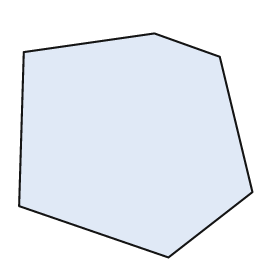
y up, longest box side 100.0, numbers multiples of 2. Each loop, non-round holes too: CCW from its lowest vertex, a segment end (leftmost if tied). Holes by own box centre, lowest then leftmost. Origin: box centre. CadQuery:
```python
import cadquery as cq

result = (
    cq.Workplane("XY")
    .moveTo(14.0, -48.0)
    .lineTo(50.0, -20.0)
    .lineTo(36.0, 38.0)
    .lineTo(8.0, 48.0)
    .lineTo(-48.0, 40.0)
    .lineTo(-50.0, -26.0)
    .close()
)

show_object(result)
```